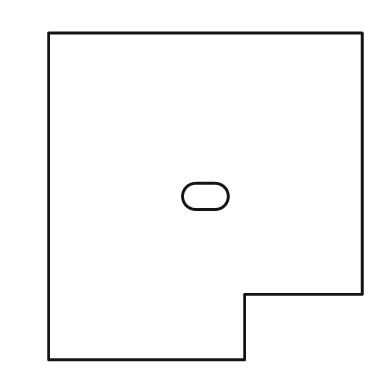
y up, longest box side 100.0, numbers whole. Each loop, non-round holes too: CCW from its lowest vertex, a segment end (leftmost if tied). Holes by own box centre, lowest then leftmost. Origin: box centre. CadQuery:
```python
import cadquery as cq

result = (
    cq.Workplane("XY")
    .moveTo(-48.0, -50.0)
    .lineTo(12.0, -50.0)
    .lineTo(12.0, -30.0)
    .lineTo(48.0, -30.0)
    .lineTo(48.0, 50.0)
    .lineTo(-48.0, 50.0)
    .close()
    .moveTo(-3.0, -4.0)
    .lineTo(3.0, -4.0)
    .threePointArc((7.0, 0.0), (3.0, 4.0))
    .lineTo(-3.0, 4.0)
    .threePointArc((-7.0, 0.0), (-3.0, -4.0))
    .close()
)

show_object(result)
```